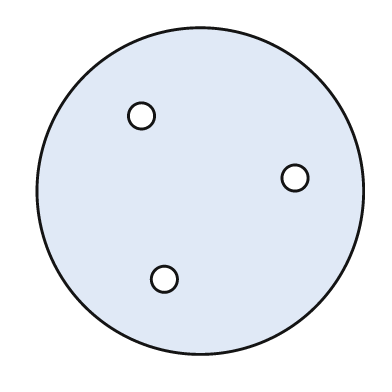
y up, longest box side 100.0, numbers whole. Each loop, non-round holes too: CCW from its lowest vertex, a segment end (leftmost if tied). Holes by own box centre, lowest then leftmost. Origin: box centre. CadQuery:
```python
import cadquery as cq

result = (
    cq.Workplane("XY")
    .moveTo(0.0, 0.0)
    .circle(50.0)
    .moveTo(-11.0, -27.0)
    .circle(4.0)
    .moveTo(29.0, 4.0)
    .circle(4.0)
    .moveTo(-18.0, 23.0)
    .circle(4.0)
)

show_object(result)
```